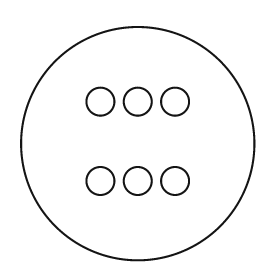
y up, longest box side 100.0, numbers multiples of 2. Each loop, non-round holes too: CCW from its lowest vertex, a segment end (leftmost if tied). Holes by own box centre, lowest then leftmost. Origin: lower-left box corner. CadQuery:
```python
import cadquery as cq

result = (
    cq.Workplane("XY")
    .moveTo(50.0, 50.0)
    .circle(50.0)
    .moveTo(34.0, 34.0)
    .circle(6.0)
    .moveTo(50.0, 34.0)
    .circle(6.0)
    .moveTo(66.0, 34.0)
    .circle(6.0)
    .moveTo(34.0, 68.0)
    .circle(6.0)
    .moveTo(50.0, 68.0)
    .circle(6.0)
    .moveTo(66.0, 68.0)
    .circle(6.0)
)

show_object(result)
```